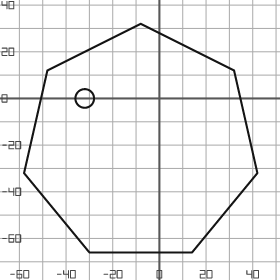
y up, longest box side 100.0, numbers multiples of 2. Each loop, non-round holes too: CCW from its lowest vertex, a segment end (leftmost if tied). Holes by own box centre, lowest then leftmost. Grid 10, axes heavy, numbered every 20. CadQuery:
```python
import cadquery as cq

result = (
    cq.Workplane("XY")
    .moveTo(-30.0, -66.0)
    .lineTo(14.0, -66.0)
    .lineTo(42.0, -32.0)
    .lineTo(32.0, 12.0)
    .lineTo(-8.0, 32.0)
    .lineTo(-48.0, 12.0)
    .lineTo(-58.0, -32.0)
    .close()
    .moveTo(-32.0, 0.0)
    .circle(4.0)
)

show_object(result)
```